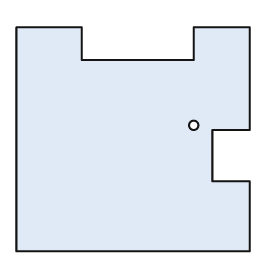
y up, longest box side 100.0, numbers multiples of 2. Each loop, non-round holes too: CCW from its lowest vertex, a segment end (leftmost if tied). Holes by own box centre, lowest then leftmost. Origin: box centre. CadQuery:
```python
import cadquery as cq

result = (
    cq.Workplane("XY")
    .moveTo(-50.0, -48.0)
    .lineTo(50.0, -48.0)
    .lineTo(50.0, -18.0)
    .lineTo(34.0, -18.0)
    .lineTo(34.0, 4.0)
    .lineTo(50.0, 4.0)
    .lineTo(50.0, 48.0)
    .lineTo(26.0, 48.0)
    .lineTo(26.0, 34.0)
    .lineTo(-22.0, 34.0)
    .lineTo(-22.0, 48.0)
    .lineTo(-50.0, 48.0)
    .close()
    .moveTo(26.0, 6.0)
    .circle(2.0)
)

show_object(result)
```